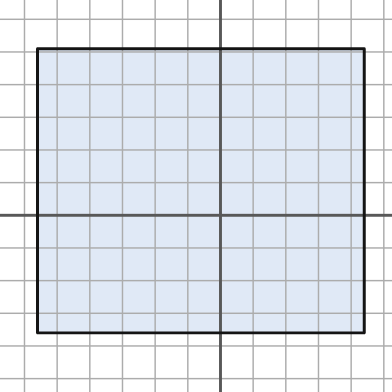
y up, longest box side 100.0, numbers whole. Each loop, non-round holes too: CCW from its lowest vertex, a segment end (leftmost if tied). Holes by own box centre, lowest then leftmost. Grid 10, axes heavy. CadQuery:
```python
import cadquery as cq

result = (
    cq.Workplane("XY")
    .moveTo(-56.0, -36.0)
    .lineTo(44.0, -36.0)
    .lineTo(44.0, 51.0)
    .lineTo(-56.0, 51.0)
    .close()
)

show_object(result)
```